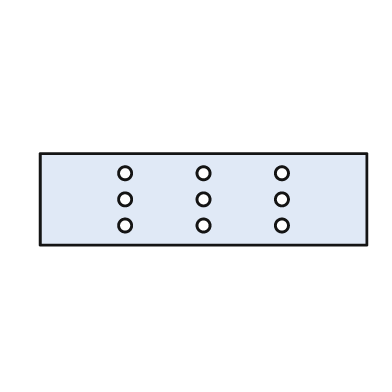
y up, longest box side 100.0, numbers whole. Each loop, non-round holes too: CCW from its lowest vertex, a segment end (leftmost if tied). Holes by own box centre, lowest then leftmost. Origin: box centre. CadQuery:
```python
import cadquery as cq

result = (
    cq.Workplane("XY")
    .moveTo(-50.0, -14.0)
    .lineTo(50.0, -14.0)
    .lineTo(50.0, 14.0)
    .lineTo(-50.0, 14.0)
    .close()
    .moveTo(-24.0, -8.0)
    .circle(2.0)
    .moveTo(0.0, -8.0)
    .circle(2.0)
    .moveTo(24.0, -8.0)
    .circle(2.0)
    .moveTo(-24.0, 0.0)
    .circle(2.0)
    .moveTo(0.0, 0.0)
    .circle(2.0)
    .moveTo(24.0, 0.0)
    .circle(2.0)
    .moveTo(-24.0, 8.0)
    .circle(2.0)
    .moveTo(0.0, 8.0)
    .circle(2.0)
    .moveTo(24.0, 8.0)
    .circle(2.0)
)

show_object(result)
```